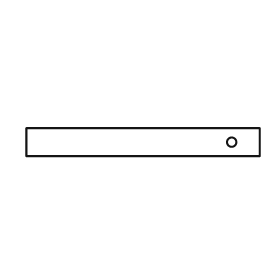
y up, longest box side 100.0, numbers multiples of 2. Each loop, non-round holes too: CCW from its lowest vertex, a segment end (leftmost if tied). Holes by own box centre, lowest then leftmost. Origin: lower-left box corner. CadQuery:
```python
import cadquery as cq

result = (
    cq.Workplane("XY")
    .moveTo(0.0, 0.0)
    .lineTo(100.0, 0.0)
    .lineTo(100.0, 12.0)
    .lineTo(0.0, 12.0)
    .close()
    .moveTo(88.0, 6.0)
    .circle(2.0)
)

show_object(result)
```